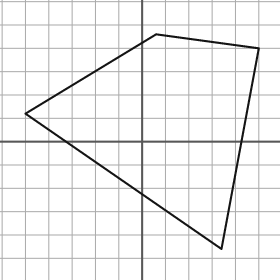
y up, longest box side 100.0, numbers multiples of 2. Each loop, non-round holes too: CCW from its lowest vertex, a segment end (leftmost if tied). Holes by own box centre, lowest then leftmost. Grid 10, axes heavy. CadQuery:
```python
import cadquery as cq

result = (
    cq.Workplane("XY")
    .moveTo(34.0, -46.0)
    .lineTo(50.0, 40.0)
    .lineTo(6.0, 46.0)
    .lineTo(-50.0, 12.0)
    .close()
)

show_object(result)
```